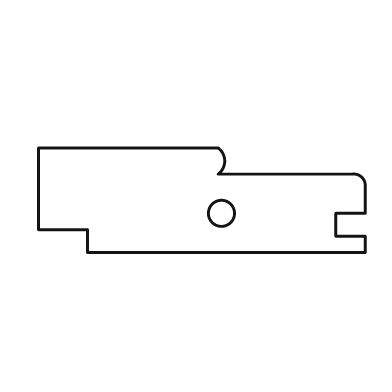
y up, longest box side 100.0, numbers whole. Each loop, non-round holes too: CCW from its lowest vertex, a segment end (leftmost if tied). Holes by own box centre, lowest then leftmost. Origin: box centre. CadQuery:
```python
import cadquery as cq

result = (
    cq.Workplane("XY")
    .moveTo(-35.0, -16.0)
    .lineTo(50.0, -16.0)
    .lineTo(50.0, -11.0)
    .lineTo(41.0, -11.0)
    .lineTo(41.0, -4.0)
    .lineTo(50.0, -4.0)
    .lineTo(50.0, 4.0)
    .threePointArc((49.0, 7.0), (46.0, 8.0))
    .lineTo(5.0, 8.0)
    .threePointArc((7.0, 12.0), (5.0, 16.0))
    .lineTo(-50.0, 16.0)
    .lineTo(-50.0, -9.0)
    .lineTo(-35.0, -9.0)
    .close()
    .moveTo(6.0, -4.0)
    .circle(4.0)
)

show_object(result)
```